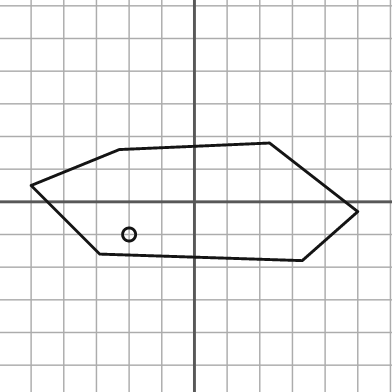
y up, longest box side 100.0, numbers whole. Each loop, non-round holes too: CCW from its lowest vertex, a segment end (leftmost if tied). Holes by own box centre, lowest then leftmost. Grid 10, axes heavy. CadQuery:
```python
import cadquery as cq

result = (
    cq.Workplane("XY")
    .moveTo(33.0, -18.0)
    .lineTo(50.0, -3.0)
    .lineTo(23.0, 18.0)
    .lineTo(-23.0, 16.0)
    .lineTo(-50.0, 5.0)
    .lineTo(-29.0, -16.0)
    .close()
    .moveTo(-20.0, -10.0)
    .circle(2.0)
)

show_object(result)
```